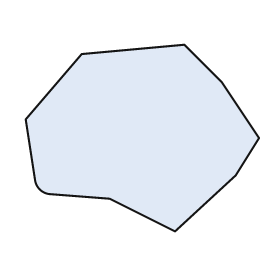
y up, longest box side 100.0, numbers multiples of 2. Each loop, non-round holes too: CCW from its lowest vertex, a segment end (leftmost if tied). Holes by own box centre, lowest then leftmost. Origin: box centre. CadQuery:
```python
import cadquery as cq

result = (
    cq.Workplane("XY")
    .moveTo(14.0, -40.0)
    .lineTo(40.0, -16.0)
    .lineTo(50.0, 0.0)
    .lineTo(34.0, 24.0)
    .lineTo(18.0, 40.0)
    .lineTo(-26.0, 36.0)
    .lineTo(-50.0, 8.0)
    .lineTo(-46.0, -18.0)
    .threePointArc((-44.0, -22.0), (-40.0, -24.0))
    .lineTo(-14.0, -26.0)
    .close()
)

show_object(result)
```